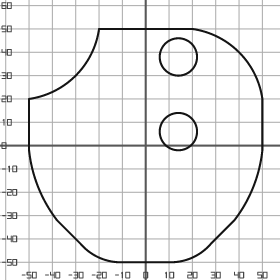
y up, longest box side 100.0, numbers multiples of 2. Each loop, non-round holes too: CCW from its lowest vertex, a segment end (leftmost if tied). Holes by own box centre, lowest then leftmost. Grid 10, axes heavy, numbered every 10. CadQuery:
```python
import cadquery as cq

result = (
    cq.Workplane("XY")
    .moveTo(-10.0, -50.0)
    .lineTo(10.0, -50.0)
    .threePointArc((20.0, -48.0), (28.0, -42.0))
    .lineTo(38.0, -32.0)
    .threePointArc((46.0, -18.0), (50.0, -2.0))
    .lineTo(50.0, 20.0)
    .threePointArc((40.0, 40.0), (20.0, 50.0))
    .lineTo(-20.0, 50.0)
    .threePointArc((-30.0, 30.0), (-50.0, 20.0))
    .lineTo(-50.0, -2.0)
    .threePointArc((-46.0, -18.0), (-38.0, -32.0))
    .lineTo(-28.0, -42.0)
    .threePointArc((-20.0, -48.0), (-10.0, -50.0))
    .close()
    .moveTo(14.0, 6.0)
    .circle(8.0)
    .moveTo(14.0, 38.0)
    .circle(8.0)
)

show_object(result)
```